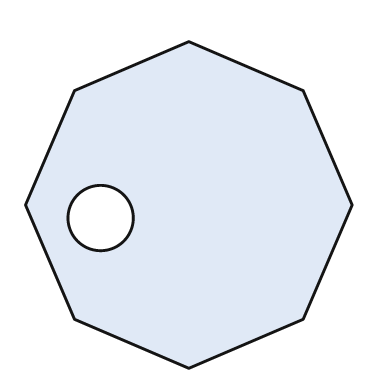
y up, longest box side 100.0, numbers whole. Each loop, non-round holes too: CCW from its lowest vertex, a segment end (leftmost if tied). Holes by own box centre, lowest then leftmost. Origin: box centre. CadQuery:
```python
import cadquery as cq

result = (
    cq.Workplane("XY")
    .moveTo(0.0, -50.0)
    .lineTo(35.0, -35.0)
    .lineTo(50.0, 0.0)
    .lineTo(35.0, 35.0)
    .lineTo(0.0, 50.0)
    .lineTo(-35.0, 35.0)
    .lineTo(-50.0, 0.0)
    .lineTo(-35.0, -35.0)
    .close()
    .moveTo(-27.0, -4.0)
    .circle(10.0)
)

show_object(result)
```